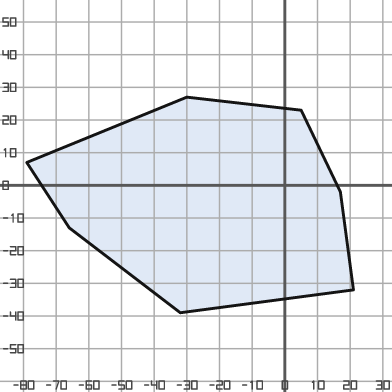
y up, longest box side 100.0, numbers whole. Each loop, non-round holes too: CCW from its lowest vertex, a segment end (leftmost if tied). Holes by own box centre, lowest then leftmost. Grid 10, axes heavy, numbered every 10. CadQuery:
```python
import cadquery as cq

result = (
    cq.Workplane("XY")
    .moveTo(-32.0, -39.0)
    .lineTo(21.0, -32.0)
    .lineTo(17.0, -2.0)
    .lineTo(5.0, 23.0)
    .lineTo(-30.0, 27.0)
    .lineTo(-79.0, 7.0)
    .lineTo(-66.0, -13.0)
    .close()
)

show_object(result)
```